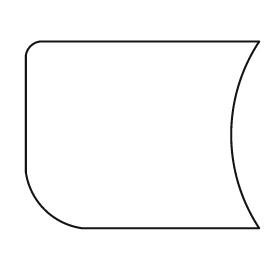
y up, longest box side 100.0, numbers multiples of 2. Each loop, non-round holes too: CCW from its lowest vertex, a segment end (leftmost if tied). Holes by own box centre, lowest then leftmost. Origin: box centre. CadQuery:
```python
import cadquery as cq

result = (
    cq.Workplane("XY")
    .moveTo(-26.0, -40.0)
    .lineTo(50.0, -40.0)
    .threePointArc((38.0, 0.0), (50.0, 40.0))
    .lineTo(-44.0, 40.0)
    .threePointArc((-48.0, 38.0), (-50.0, 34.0))
    .lineTo(-50.0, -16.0)
    .threePointArc((-42.0, -32.0), (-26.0, -40.0))
    .close()
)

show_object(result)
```